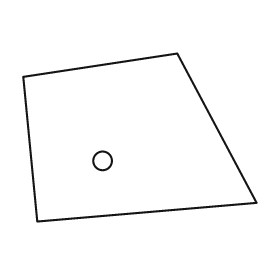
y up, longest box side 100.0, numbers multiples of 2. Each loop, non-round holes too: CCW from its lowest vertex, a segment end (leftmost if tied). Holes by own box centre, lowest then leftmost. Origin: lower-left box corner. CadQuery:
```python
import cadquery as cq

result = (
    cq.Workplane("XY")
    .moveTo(6.0, 0.0)
    .lineTo(100.0, 8.0)
    .lineTo(66.0, 72.0)
    .lineTo(0.0, 62.0)
    .close()
    .moveTo(34.0, 26.0)
    .circle(4.0)
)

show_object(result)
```